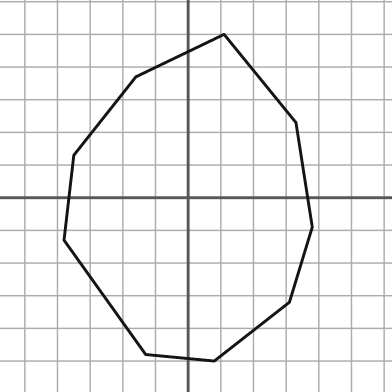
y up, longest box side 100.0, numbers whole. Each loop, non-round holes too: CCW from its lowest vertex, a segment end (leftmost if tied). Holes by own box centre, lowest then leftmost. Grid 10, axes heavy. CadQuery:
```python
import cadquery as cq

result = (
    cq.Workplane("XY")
    .moveTo(8.0, -50.0)
    .lineTo(31.0, -32.0)
    .lineTo(38.0, -9.0)
    .lineTo(33.0, 23.0)
    .lineTo(11.0, 50.0)
    .lineTo(-16.0, 37.0)
    .lineTo(-35.0, 13.0)
    .lineTo(-38.0, -13.0)
    .lineTo(-13.0, -48.0)
    .close()
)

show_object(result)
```